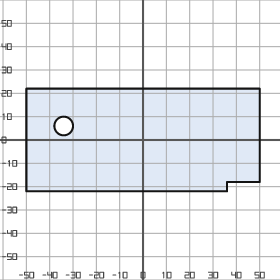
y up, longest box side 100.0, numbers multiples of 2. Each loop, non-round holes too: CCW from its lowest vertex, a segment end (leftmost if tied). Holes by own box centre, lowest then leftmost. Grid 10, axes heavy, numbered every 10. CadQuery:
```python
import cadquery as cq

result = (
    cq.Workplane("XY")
    .moveTo(-50.0, -22.0)
    .lineTo(36.0, -22.0)
    .lineTo(36.0, -18.0)
    .lineTo(50.0, -18.0)
    .lineTo(50.0, 22.0)
    .lineTo(-50.0, 22.0)
    .close()
    .moveTo(-34.0, 6.0)
    .circle(4.0)
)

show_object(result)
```